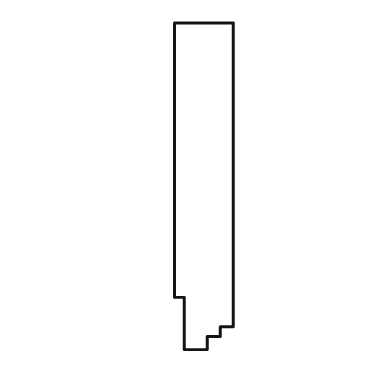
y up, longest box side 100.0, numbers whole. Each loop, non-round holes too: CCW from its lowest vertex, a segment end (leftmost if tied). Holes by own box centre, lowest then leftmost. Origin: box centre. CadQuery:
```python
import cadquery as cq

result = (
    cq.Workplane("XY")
    .moveTo(-6.0, -50.0)
    .lineTo(1.0, -50.0)
    .lineTo(1.0, -46.0)
    .lineTo(5.0, -46.0)
    .lineTo(5.0, -43.0)
    .lineTo(9.0, -43.0)
    .lineTo(9.0, 50.0)
    .lineTo(-9.0, 50.0)
    .lineTo(-9.0, -34.0)
    .lineTo(-6.0, -34.0)
    .close()
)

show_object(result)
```